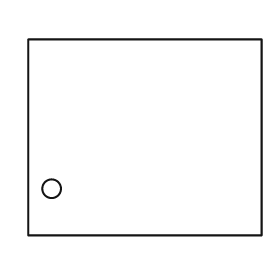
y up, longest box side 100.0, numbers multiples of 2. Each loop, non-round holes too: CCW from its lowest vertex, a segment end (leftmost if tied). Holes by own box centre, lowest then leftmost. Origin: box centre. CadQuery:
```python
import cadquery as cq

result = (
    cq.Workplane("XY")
    .moveTo(-50.0, -42.0)
    .lineTo(50.0, -42.0)
    .lineTo(50.0, 42.0)
    .lineTo(-50.0, 42.0)
    .close()
    .moveTo(-40.0, -22.0)
    .circle(4.0)
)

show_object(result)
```